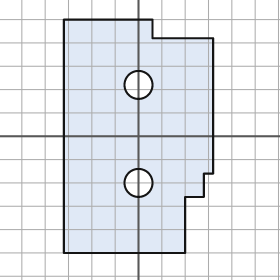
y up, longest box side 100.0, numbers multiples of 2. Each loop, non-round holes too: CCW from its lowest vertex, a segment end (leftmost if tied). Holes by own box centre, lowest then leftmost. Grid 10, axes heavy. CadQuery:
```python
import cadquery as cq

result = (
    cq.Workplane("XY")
    .moveTo(-32.0, -50.0)
    .lineTo(20.0, -50.0)
    .lineTo(20.0, -26.0)
    .lineTo(28.0, -26.0)
    .lineTo(28.0, -16.0)
    .lineTo(32.0, -16.0)
    .lineTo(32.0, 42.0)
    .lineTo(6.0, 42.0)
    .lineTo(6.0, 50.0)
    .lineTo(-32.0, 50.0)
    .close()
    .moveTo(0.0, -20.0)
    .circle(6.0)
    .moveTo(0.0, 22.0)
    .circle(6.0)
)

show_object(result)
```